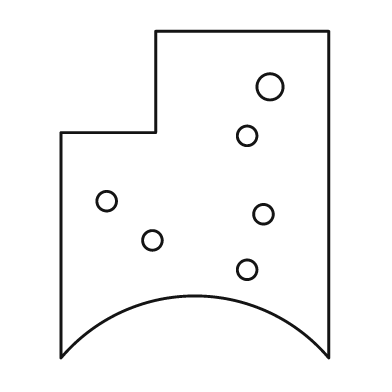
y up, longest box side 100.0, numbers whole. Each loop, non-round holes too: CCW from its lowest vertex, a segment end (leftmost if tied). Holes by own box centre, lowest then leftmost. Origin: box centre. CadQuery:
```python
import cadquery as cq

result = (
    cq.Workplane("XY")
    .moveTo(-41.0, -50.0)
    .threePointArc((0.0, -31.0), (41.0, -50.0))
    .lineTo(41.0, 50.0)
    .lineTo(-12.0, 50.0)
    .lineTo(-12.0, 19.0)
    .lineTo(-41.0, 19.0)
    .close()
    .moveTo(16.0, -23.0)
    .circle(3.0)
    .moveTo(-13.0, -14.0)
    .circle(3.0)
    .moveTo(21.0, -6.0)
    .circle(3.0)
    .moveTo(-27.0, -2.0)
    .circle(3.0)
    .moveTo(16.0, 18.0)
    .circle(3.0)
    .moveTo(23.0, 33.0)
    .circle(4.0)
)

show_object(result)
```